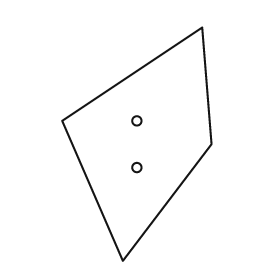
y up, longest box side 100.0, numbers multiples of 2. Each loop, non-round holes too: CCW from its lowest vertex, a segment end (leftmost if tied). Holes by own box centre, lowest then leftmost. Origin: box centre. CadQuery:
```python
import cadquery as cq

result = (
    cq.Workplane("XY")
    .moveTo(-6.0, -50.0)
    .lineTo(32.0, 0.0)
    .lineTo(28.0, 50.0)
    .lineTo(-32.0, 10.0)
    .close()
    .moveTo(0.0, -10.0)
    .circle(2.0)
    .moveTo(0.0, 10.0)
    .circle(2.0)
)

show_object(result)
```